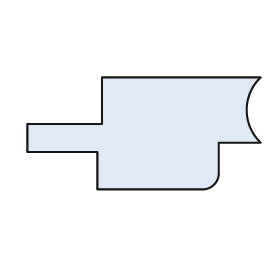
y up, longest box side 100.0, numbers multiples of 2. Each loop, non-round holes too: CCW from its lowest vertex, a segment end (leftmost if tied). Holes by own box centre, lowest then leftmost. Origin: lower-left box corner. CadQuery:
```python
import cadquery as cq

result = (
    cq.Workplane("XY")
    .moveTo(30.0, 0.0)
    .lineTo(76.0, 0.0)
    .threePointArc((80.0, 2.0), (82.0, 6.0))
    .lineTo(82.0, 20.0)
    .lineTo(100.0, 20.0)
    .threePointArc((94.0, 34.0), (100.0, 48.0))
    .lineTo(32.0, 48.0)
    .lineTo(32.0, 28.0)
    .lineTo(0.0, 28.0)
    .lineTo(0.0, 16.0)
    .lineTo(30.0, 16.0)
    .close()
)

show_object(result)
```